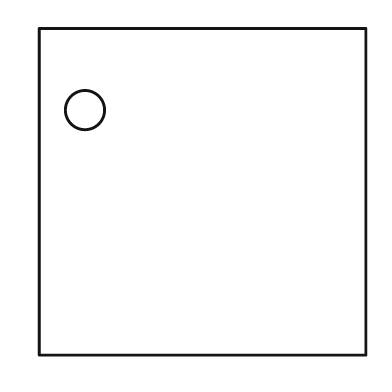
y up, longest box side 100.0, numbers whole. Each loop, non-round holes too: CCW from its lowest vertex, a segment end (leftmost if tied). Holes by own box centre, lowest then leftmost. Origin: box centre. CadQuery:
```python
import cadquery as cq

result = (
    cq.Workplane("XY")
    .moveTo(-50.0, -50.0)
    .lineTo(50.0, -50.0)
    .lineTo(50.0, 50.0)
    .lineTo(-50.0, 50.0)
    .close()
    .moveTo(-36.0, 25.0)
    .circle(6.0)
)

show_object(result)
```